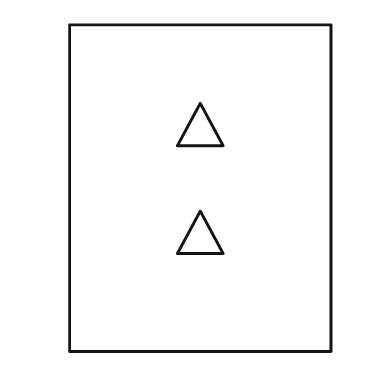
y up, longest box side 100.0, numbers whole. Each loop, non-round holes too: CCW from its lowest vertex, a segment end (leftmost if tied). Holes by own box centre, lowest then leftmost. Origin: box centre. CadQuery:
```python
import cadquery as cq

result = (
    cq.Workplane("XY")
    .moveTo(-40.0, -50.0)
    .lineTo(40.0, -50.0)
    .lineTo(40.0, 50.0)
    .lineTo(-40.0, 50.0)
    .close()
    .moveTo(-7.0, -20.0)
    .lineTo(7.0, -20.0)
    .lineTo(0.0, -7.0)
    .close()
    .moveTo(-7.0, 13.0)
    .lineTo(7.0, 13.0)
    .lineTo(0.0, 26.0)
    .close()
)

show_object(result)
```